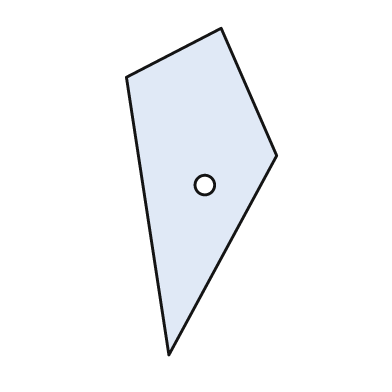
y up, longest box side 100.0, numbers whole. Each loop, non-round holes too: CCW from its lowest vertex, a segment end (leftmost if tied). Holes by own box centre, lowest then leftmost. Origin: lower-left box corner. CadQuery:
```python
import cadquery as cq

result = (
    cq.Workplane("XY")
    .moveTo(13.0, 0.0)
    .lineTo(46.0, 61.0)
    .lineTo(29.0, 100.0)
    .lineTo(0.0, 85.0)
    .close()
    .moveTo(24.0, 52.0)
    .circle(3.0)
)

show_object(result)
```